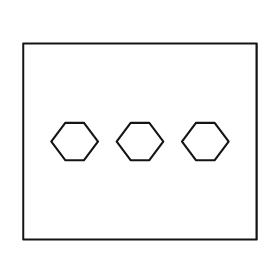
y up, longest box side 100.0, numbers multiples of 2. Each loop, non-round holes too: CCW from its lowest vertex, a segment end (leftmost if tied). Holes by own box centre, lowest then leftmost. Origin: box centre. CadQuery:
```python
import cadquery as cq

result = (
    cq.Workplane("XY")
    .moveTo(-50.0, -42.0)
    .lineTo(50.0, -42.0)
    .lineTo(50.0, 42.0)
    .lineTo(-50.0, 42.0)
    .close()
    .moveTo(-32.0, -8.0)
    .lineTo(-24.0, -8.0)
    .lineTo(-18.0, 0.0)
    .lineTo(-24.0, 8.0)
    .lineTo(-32.0, 8.0)
    .lineTo(-38.0, 0.0)
    .close()
    .moveTo(-4.0, -8.0)
    .lineTo(4.0, -8.0)
    .lineTo(10.0, 0.0)
    .lineTo(4.0, 8.0)
    .lineTo(-4.0, 8.0)
    .lineTo(-10.0, 0.0)
    .close()
    .moveTo(24.0, -8.0)
    .lineTo(32.0, -8.0)
    .lineTo(38.0, 0.0)
    .lineTo(32.0, 8.0)
    .lineTo(24.0, 8.0)
    .lineTo(18.0, 0.0)
    .close()
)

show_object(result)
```